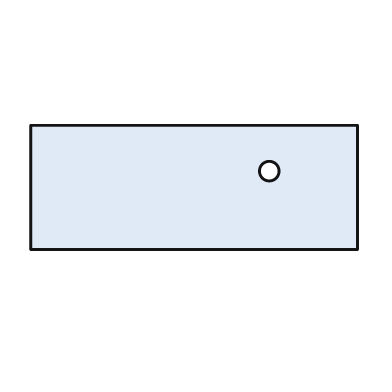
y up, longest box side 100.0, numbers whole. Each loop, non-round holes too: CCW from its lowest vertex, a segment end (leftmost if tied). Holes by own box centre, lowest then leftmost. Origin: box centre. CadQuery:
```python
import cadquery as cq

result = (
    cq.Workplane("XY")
    .moveTo(-50.0, -19.0)
    .lineTo(50.0, -19.0)
    .lineTo(50.0, 19.0)
    .lineTo(-50.0, 19.0)
    .close()
    .moveTo(23.0, 5.0)
    .circle(3.0)
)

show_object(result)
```